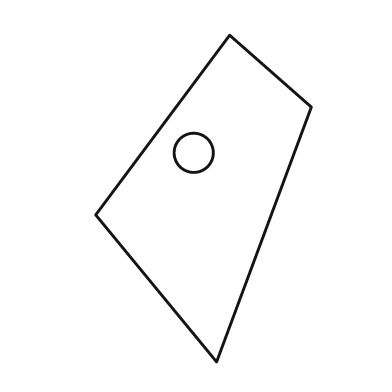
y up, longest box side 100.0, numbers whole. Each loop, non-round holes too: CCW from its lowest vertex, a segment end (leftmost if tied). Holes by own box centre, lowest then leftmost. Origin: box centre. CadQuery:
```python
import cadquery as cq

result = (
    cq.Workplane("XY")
    .moveTo(4.0, -50.0)
    .lineTo(33.0, 28.0)
    .lineTo(8.0, 50.0)
    .lineTo(-33.0, -5.0)
    .close()
    .moveTo(-3.0, 14.0)
    .circle(6.0)
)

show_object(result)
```